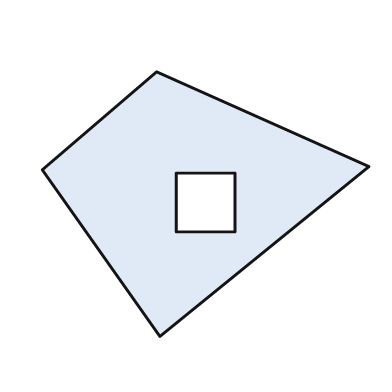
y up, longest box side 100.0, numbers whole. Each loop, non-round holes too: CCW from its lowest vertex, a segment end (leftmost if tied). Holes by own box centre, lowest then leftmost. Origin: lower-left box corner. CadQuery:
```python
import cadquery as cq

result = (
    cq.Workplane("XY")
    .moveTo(36.0, 0.0)
    .lineTo(100.0, 52.0)
    .lineTo(35.0, 81.0)
    .lineTo(0.0, 51.0)
    .close()
    .moveTo(41.0, 32.0)
    .lineTo(59.0, 32.0)
    .lineTo(59.0, 50.0)
    .lineTo(41.0, 50.0)
    .close()
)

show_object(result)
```